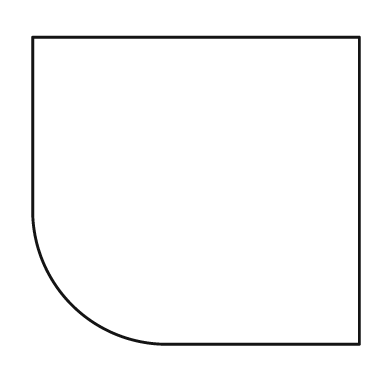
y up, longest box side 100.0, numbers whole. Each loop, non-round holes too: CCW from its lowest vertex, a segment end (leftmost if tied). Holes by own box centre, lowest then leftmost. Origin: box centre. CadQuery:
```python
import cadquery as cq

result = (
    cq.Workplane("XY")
    .moveTo(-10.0, -47.0)
    .lineTo(50.0, -47.0)
    .lineTo(50.0, 47.0)
    .lineTo(-50.0, 47.0)
    .lineTo(-50.0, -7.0)
    .threePointArc((-38.0, -35.0), (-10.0, -47.0))
    .close()
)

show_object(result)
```